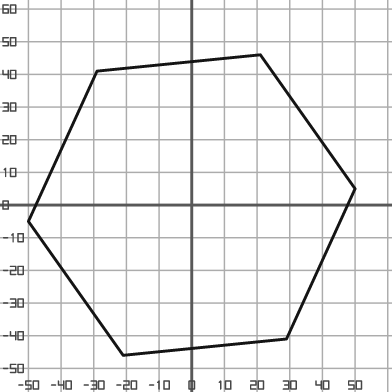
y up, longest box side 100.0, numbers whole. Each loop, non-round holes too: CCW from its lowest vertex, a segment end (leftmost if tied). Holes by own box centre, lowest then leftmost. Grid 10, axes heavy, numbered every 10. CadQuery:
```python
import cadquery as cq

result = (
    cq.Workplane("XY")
    .moveTo(-21.0, -46.0)
    .lineTo(29.0, -41.0)
    .lineTo(50.0, 5.0)
    .lineTo(21.0, 46.0)
    .lineTo(-29.0, 41.0)
    .lineTo(-50.0, -5.0)
    .close()
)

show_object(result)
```